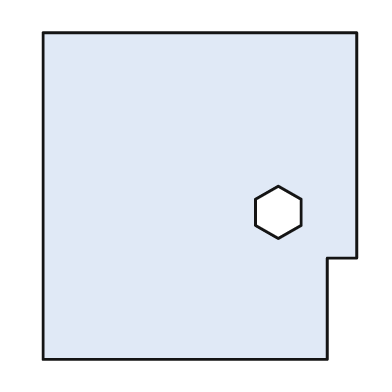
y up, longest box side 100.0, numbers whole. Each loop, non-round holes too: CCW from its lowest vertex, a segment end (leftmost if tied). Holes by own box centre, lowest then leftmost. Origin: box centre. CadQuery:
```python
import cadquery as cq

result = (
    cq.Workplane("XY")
    .moveTo(-48.0, -50.0)
    .lineTo(39.0, -50.0)
    .lineTo(39.0, -19.0)
    .lineTo(48.0, -19.0)
    .lineTo(48.0, 50.0)
    .lineTo(-48.0, 50.0)
    .close()
    .moveTo(24.0, -13.0)
    .lineTo(31.0, -9.0)
    .lineTo(31.0, -1.0)
    .lineTo(24.0, 3.0)
    .lineTo(17.0, -1.0)
    .lineTo(17.0, -9.0)
    .close()
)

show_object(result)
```